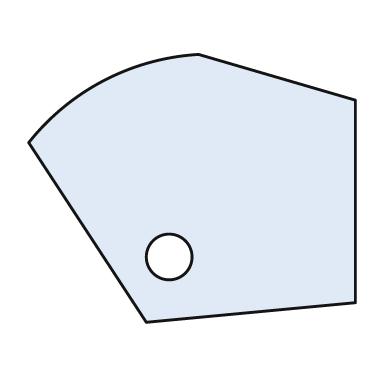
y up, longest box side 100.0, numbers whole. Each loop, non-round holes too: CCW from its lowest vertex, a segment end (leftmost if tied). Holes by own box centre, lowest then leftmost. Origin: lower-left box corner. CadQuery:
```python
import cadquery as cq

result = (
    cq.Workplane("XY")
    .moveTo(36.0, 0.0)
    .lineTo(100.0, 6.0)
    .lineTo(100.0, 68.0)
    .lineTo(52.0, 82.0)
    .threePointArc((23.0, 74.0), (0.0, 55.0))
    .close()
    .moveTo(43.0, 20.0)
    .circle(7.0)
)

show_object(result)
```